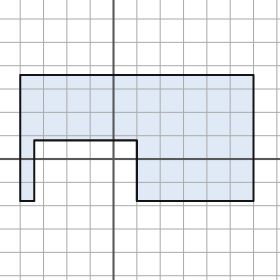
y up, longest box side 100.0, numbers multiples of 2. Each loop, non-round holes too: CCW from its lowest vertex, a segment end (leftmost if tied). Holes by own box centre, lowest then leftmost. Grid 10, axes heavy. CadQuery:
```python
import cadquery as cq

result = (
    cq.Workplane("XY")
    .moveTo(-40.0, -18.0)
    .lineTo(-34.0, -18.0)
    .lineTo(-34.0, 8.0)
    .lineTo(10.0, 8.0)
    .lineTo(10.0, -18.0)
    .lineTo(60.0, -18.0)
    .lineTo(60.0, 36.0)
    .lineTo(-40.0, 36.0)
    .close()
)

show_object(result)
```